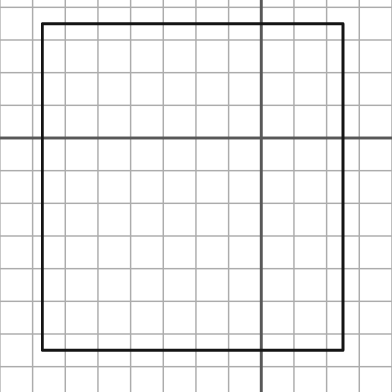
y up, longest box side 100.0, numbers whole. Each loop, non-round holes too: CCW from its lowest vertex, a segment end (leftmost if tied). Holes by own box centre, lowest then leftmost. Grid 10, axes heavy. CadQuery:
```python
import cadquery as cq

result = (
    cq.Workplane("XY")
    .moveTo(-67.0, -65.0)
    .lineTo(25.0, -65.0)
    .lineTo(25.0, 35.0)
    .lineTo(-67.0, 35.0)
    .close()
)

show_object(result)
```